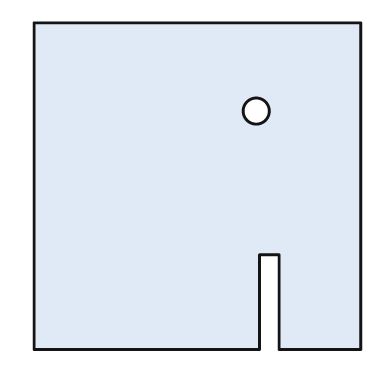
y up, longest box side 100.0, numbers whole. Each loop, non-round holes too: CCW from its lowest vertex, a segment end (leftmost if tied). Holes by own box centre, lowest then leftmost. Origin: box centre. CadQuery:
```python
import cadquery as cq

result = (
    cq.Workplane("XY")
    .moveTo(-50.0, -50.0)
    .lineTo(19.0, -50.0)
    .lineTo(19.0, -21.0)
    .lineTo(25.0, -21.0)
    .lineTo(25.0, -50.0)
    .lineTo(50.0, -50.0)
    .lineTo(50.0, 50.0)
    .lineTo(-50.0, 50.0)
    .close()
    .moveTo(18.0, 23.0)
    .circle(4.0)
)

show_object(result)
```